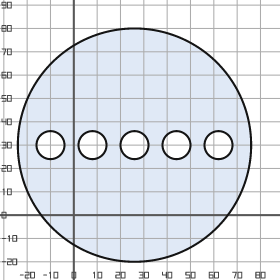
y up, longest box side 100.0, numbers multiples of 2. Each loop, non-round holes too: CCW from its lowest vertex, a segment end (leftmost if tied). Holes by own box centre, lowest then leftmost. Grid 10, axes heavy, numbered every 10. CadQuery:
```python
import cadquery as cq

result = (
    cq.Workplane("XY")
    .moveTo(26.0, 30.0)
    .circle(50.0)
    .moveTo(-10.0, 30.0)
    .circle(6.0)
    .moveTo(8.0, 30.0)
    .circle(6.0)
    .moveTo(26.0, 30.0)
    .circle(6.0)
    .moveTo(44.0, 30.0)
    .circle(6.0)
    .moveTo(62.0, 30.0)
    .circle(6.0)
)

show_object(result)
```